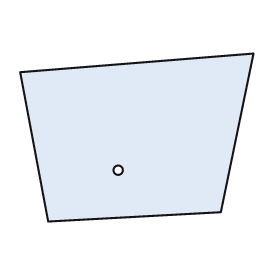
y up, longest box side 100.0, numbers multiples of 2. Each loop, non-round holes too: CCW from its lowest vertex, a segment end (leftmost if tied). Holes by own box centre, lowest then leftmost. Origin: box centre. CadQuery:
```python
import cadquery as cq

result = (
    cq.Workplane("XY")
    .moveTo(-38.0, -36.0)
    .lineTo(36.0, -32.0)
    .lineTo(50.0, 36.0)
    .lineTo(-50.0, 28.0)
    .close()
    .moveTo(-8.0, -14.0)
    .circle(2.0)
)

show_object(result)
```